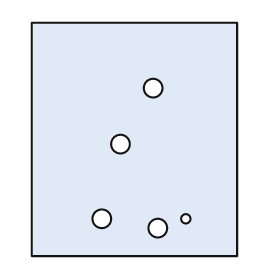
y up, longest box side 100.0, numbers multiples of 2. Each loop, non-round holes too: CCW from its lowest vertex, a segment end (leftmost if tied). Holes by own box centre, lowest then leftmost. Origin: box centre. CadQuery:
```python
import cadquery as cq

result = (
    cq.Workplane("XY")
    .moveTo(-44.0, -50.0)
    .lineTo(44.0, -50.0)
    .lineTo(44.0, 50.0)
    .lineTo(-44.0, 50.0)
    .close()
    .moveTo(10.0, -38.0)
    .circle(4.0)
    .moveTo(-14.0, -34.0)
    .circle(4.0)
    .moveTo(22.0, -34.0)
    .circle(2.0)
    .moveTo(-6.0, -2.0)
    .circle(4.0)
    .moveTo(8.0, 22.0)
    .circle(4.0)
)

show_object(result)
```